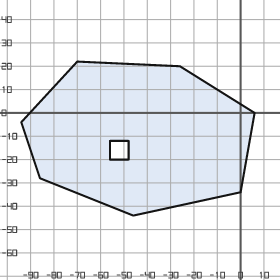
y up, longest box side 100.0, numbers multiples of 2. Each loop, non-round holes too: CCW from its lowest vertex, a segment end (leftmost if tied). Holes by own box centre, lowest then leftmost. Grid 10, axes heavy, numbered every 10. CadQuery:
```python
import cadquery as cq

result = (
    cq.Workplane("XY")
    .moveTo(-46.0, -44.0)
    .lineTo(0.0, -34.0)
    .lineTo(6.0, 0.0)
    .lineTo(-26.0, 20.0)
    .lineTo(-70.0, 22.0)
    .lineTo(-94.0, -4.0)
    .lineTo(-86.0, -28.0)
    .close()
    .moveTo(-56.0, -20.0)
    .lineTo(-48.0, -20.0)
    .lineTo(-48.0, -12.0)
    .lineTo(-56.0, -12.0)
    .close()
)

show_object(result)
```